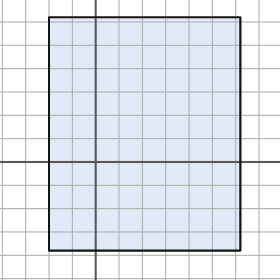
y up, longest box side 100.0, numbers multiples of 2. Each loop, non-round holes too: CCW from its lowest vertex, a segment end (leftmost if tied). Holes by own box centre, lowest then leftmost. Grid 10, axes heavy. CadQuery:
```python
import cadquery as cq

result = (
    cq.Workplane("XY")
    .moveTo(-20.0, -38.0)
    .lineTo(62.0, -38.0)
    .lineTo(62.0, 62.0)
    .lineTo(-20.0, 62.0)
    .close()
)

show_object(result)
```